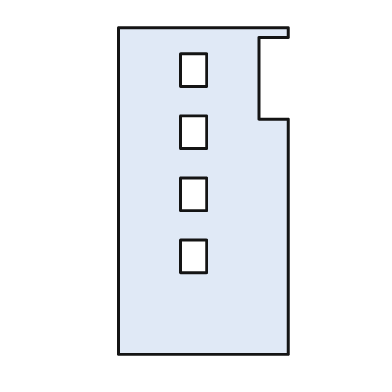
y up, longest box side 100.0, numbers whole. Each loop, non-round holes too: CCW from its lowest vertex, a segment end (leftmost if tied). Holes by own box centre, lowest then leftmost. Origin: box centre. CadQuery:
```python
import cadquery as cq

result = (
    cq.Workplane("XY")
    .moveTo(-26.0, -50.0)
    .lineTo(26.0, -50.0)
    .lineTo(26.0, 22.0)
    .lineTo(17.0, 22.0)
    .lineTo(17.0, 47.0)
    .lineTo(26.0, 47.0)
    .lineTo(26.0, 50.0)
    .lineTo(-26.0, 50.0)
    .close()
    .moveTo(-7.0, -25.0)
    .lineTo(1.0, -25.0)
    .lineTo(1.0, -15.0)
    .lineTo(-7.0, -15.0)
    .close()
    .moveTo(-7.0, -6.0)
    .lineTo(1.0, -6.0)
    .lineTo(1.0, 4.0)
    .lineTo(-7.0, 4.0)
    .close()
    .moveTo(-7.0, 13.0)
    .lineTo(1.0, 13.0)
    .lineTo(1.0, 23.0)
    .lineTo(-7.0, 23.0)
    .close()
    .moveTo(-7.0, 32.0)
    .lineTo(1.0, 32.0)
    .lineTo(1.0, 42.0)
    .lineTo(-7.0, 42.0)
    .close()
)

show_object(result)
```